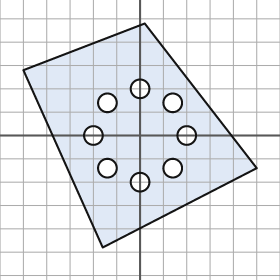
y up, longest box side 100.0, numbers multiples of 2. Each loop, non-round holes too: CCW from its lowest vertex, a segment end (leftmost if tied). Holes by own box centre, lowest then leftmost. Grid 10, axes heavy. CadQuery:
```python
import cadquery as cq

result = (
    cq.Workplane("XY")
    .moveTo(-16.0, -48.0)
    .lineTo(50.0, -14.0)
    .lineTo(2.0, 48.0)
    .lineTo(-50.0, 28.0)
    .close()
    .moveTo(0.0, -20.0)
    .circle(4.0)
    .moveTo(-14.0, -14.0)
    .circle(4.0)
    .moveTo(14.0, -14.0)
    .circle(4.0)
    .moveTo(-20.0, 0.0)
    .circle(4.0)
    .moveTo(20.0, 0.0)
    .circle(4.0)
    .moveTo(-14.0, 14.0)
    .circle(4.0)
    .moveTo(14.0, 14.0)
    .circle(4.0)
    .moveTo(0.0, 20.0)
    .circle(4.0)
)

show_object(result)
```